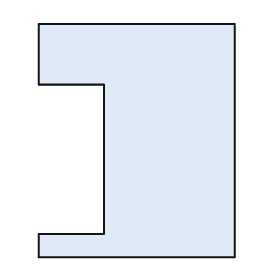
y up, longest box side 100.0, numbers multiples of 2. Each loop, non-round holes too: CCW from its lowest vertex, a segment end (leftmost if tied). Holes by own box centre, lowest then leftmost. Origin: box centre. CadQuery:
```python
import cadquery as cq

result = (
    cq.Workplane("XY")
    .moveTo(-42.0, -50.0)
    .lineTo(42.0, -50.0)
    .lineTo(42.0, 50.0)
    .lineTo(-42.0, 50.0)
    .lineTo(-42.0, 24.0)
    .lineTo(-14.0, 24.0)
    .lineTo(-14.0, -40.0)
    .lineTo(-42.0, -40.0)
    .close()
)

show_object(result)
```